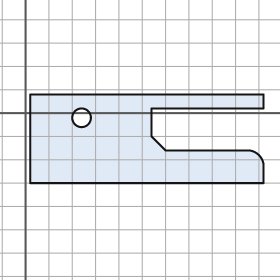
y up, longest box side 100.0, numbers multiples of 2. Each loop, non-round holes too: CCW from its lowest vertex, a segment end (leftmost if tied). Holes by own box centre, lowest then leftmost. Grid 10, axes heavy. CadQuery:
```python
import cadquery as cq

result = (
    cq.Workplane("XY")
    .moveTo(2.0, -30.0)
    .lineTo(102.0, -30.0)
    .lineTo(102.0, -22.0)
    .threePointArc((100.0, -18.0), (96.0, -16.0))
    .lineTo(60.0, -16.0)
    .lineTo(54.0, -10.0)
    .lineTo(54.0, 2.0)
    .lineTo(102.0, 2.0)
    .lineTo(102.0, 8.0)
    .lineTo(2.0, 8.0)
    .close()
    .moveTo(24.0, -2.0)
    .circle(4.0)
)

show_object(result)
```